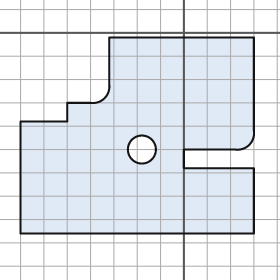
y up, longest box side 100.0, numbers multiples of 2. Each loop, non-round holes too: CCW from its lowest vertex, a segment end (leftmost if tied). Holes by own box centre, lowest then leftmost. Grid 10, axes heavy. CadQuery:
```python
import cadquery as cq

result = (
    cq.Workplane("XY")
    .moveTo(-70.0, -86.0)
    .lineTo(30.0, -86.0)
    .lineTo(30.0, -58.0)
    .lineTo(0.0, -58.0)
    .lineTo(0.0, -50.0)
    .lineTo(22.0, -50.0)
    .threePointArc((28.0, -48.0), (30.0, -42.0))
    .lineTo(30.0, -2.0)
    .lineTo(-32.0, -2.0)
    .lineTo(-32.0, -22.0)
    .threePointArc((-34.0, -28.0), (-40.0, -30.0))
    .lineTo(-50.0, -30.0)
    .lineTo(-50.0, -38.0)
    .lineTo(-70.0, -38.0)
    .close()
    .moveTo(-18.0, -50.0)
    .circle(6.0)
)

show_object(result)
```